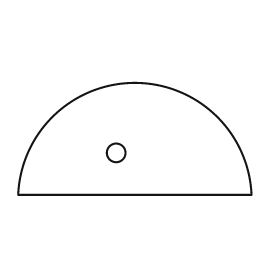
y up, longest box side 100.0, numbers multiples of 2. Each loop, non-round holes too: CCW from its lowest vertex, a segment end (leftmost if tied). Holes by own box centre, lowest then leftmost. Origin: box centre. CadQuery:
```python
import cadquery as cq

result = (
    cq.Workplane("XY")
    .moveTo(-50.0, -24.0)
    .lineTo(50.0, -24.0)
    .threePointArc((0.0, 24.0), (-50.0, -24.0))
    .close()
    .moveTo(-8.0, -6.0)
    .circle(4.0)
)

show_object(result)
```